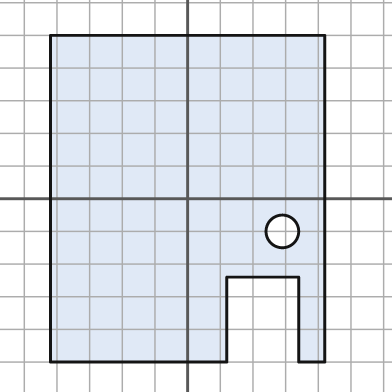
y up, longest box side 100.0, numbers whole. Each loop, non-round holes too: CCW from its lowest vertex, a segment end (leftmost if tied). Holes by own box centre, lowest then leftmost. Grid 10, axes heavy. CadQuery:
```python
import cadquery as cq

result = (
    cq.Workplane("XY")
    .moveTo(-42.0, -50.0)
    .lineTo(12.0, -50.0)
    .lineTo(12.0, -24.0)
    .lineTo(34.0, -24.0)
    .lineTo(34.0, -50.0)
    .lineTo(42.0, -50.0)
    .lineTo(42.0, 50.0)
    .lineTo(-42.0, 50.0)
    .close()
    .moveTo(29.0, -10.0)
    .circle(5.0)
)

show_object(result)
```